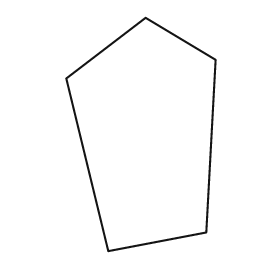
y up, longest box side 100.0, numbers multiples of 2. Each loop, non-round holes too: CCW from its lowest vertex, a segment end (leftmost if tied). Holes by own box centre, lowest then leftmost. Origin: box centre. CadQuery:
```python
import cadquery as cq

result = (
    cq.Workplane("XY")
    .moveTo(-14.0, -50.0)
    .lineTo(28.0, -42.0)
    .lineTo(32.0, 32.0)
    .lineTo(2.0, 50.0)
    .lineTo(-32.0, 24.0)
    .close()
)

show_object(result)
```